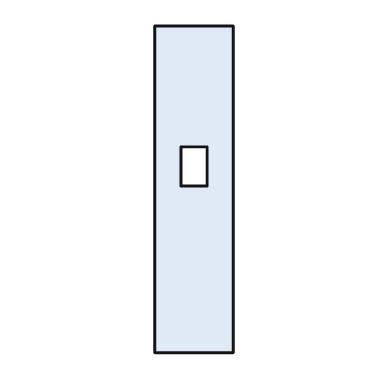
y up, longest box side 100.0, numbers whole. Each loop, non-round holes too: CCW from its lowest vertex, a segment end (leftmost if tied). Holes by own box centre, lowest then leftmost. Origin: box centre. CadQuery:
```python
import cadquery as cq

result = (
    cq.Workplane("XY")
    .moveTo(-12.0, -50.0)
    .lineTo(12.0, -50.0)
    .lineTo(12.0, 50.0)
    .lineTo(-12.0, 50.0)
    .close()
    .moveTo(-4.0, 1.0)
    .lineTo(4.0, 1.0)
    .lineTo(4.0, 13.0)
    .lineTo(-4.0, 13.0)
    .close()
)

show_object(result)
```